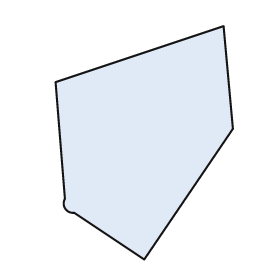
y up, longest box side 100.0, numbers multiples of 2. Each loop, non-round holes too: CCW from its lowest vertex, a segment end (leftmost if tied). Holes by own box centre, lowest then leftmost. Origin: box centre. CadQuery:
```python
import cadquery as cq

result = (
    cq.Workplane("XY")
    .moveTo(0.0, -50.0)
    .lineTo(38.0, 6.0)
    .lineTo(34.0, 50.0)
    .lineTo(-38.0, 26.0)
    .lineTo(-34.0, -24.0)
    .threePointArc((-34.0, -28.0), (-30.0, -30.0))
    .close()
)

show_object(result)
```